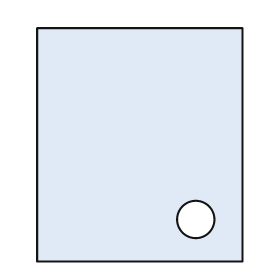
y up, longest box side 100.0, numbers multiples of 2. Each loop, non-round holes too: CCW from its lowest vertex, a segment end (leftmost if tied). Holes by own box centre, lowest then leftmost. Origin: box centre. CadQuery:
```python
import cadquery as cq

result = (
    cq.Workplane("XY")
    .moveTo(-44.0, -50.0)
    .lineTo(44.0, -50.0)
    .lineTo(44.0, 50.0)
    .lineTo(-44.0, 50.0)
    .close()
    .moveTo(24.0, -32.0)
    .circle(8.0)
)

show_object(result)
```